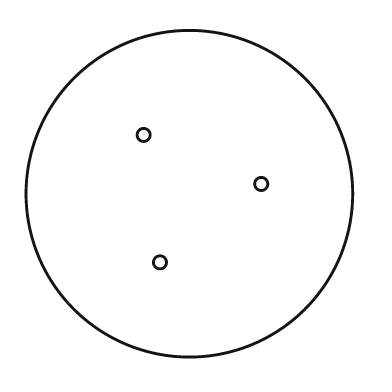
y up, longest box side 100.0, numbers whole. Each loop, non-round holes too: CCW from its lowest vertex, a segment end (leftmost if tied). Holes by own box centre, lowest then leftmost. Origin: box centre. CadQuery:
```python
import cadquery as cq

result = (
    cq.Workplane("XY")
    .moveTo(0.0, 0.0)
    .circle(50.0)
    .moveTo(-9.0, -21.0)
    .circle(2.0)
    .moveTo(22.0, 3.0)
    .circle(2.0)
    .moveTo(-14.0, 18.0)
    .circle(2.0)
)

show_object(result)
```